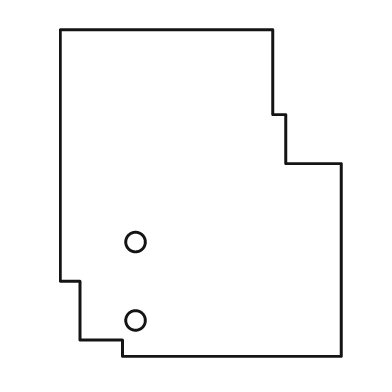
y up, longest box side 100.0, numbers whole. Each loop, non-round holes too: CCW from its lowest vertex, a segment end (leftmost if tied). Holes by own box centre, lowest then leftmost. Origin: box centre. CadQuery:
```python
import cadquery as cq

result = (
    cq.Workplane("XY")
    .moveTo(-24.0, -50.0)
    .lineTo(43.0, -50.0)
    .lineTo(43.0, 9.0)
    .lineTo(26.0, 9.0)
    .lineTo(26.0, 24.0)
    .lineTo(22.0, 24.0)
    .lineTo(22.0, 50.0)
    .lineTo(-43.0, 50.0)
    .lineTo(-43.0, -27.0)
    .lineTo(-37.0, -27.0)
    .lineTo(-37.0, -45.0)
    .lineTo(-24.0, -45.0)
    .close()
    .moveTo(-20.0, -39.0)
    .circle(3.0)
    .moveTo(-20.0, -15.0)
    .circle(3.0)
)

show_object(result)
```